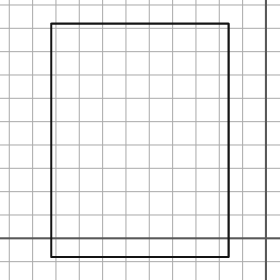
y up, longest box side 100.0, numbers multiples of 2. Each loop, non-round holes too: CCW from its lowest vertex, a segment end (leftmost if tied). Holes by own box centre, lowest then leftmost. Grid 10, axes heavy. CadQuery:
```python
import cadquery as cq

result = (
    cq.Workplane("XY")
    .moveTo(-92.0, -8.0)
    .lineTo(-16.0, -8.0)
    .lineTo(-16.0, 92.0)
    .lineTo(-92.0, 92.0)
    .close()
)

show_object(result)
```